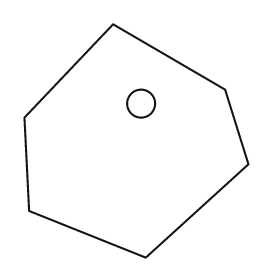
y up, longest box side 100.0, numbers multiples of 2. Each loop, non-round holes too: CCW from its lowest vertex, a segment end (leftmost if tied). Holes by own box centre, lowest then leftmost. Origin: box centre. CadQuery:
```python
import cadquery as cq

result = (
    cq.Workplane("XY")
    .moveTo(4.0, -50.0)
    .lineTo(48.0, -10.0)
    .lineTo(38.0, 22.0)
    .lineTo(-10.0, 50.0)
    .lineTo(-48.0, 10.0)
    .lineTo(-46.0, -30.0)
    .close()
    .moveTo(2.0, 16.0)
    .circle(6.0)
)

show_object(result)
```